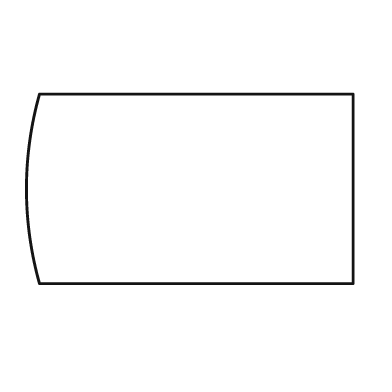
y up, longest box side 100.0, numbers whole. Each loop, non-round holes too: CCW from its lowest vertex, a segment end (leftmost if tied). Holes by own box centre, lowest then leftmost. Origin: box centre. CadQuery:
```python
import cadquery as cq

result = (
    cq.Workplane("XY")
    .moveTo(-46.0, -29.0)
    .lineTo(50.0, -29.0)
    .lineTo(50.0, 29.0)
    .lineTo(-46.0, 29.0)
    .threePointArc((-50.0, 0.0), (-46.0, -29.0))
    .close()
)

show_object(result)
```